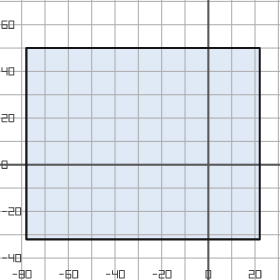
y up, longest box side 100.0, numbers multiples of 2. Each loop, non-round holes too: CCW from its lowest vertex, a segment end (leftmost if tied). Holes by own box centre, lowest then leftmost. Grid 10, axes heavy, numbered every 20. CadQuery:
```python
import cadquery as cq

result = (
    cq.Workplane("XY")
    .moveTo(-78.0, -32.0)
    .lineTo(22.0, -32.0)
    .lineTo(22.0, 50.0)
    .lineTo(-78.0, 50.0)
    .close()
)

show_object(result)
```